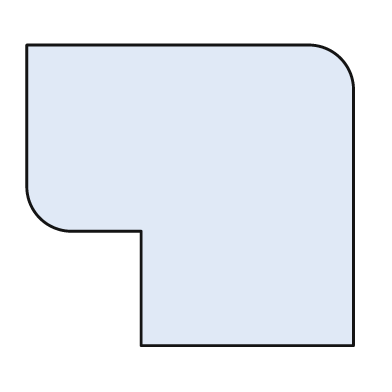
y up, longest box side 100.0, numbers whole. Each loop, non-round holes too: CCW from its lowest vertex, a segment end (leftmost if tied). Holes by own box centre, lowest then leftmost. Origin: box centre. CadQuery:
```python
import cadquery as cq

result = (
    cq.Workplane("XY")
    .moveTo(-15.0, -46.0)
    .lineTo(50.0, -46.0)
    .lineTo(50.0, 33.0)
    .threePointArc((46.0, 42.0), (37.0, 46.0))
    .lineTo(-50.0, 46.0)
    .lineTo(-50.0, 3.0)
    .threePointArc((-46.0, -7.0), (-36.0, -11.0))
    .lineTo(-15.0, -11.0)
    .close()
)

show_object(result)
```